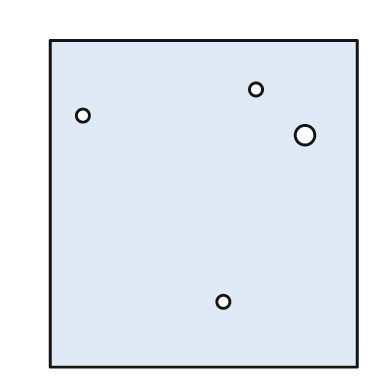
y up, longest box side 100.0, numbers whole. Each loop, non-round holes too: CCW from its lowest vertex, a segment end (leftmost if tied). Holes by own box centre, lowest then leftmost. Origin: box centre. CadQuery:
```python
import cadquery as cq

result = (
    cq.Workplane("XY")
    .moveTo(-47.0, -50.0)
    .lineTo(47.0, -50.0)
    .lineTo(47.0, 50.0)
    .lineTo(-47.0, 50.0)
    .close()
    .moveTo(6.0, -30.0)
    .circle(2.0)
    .moveTo(31.0, 21.0)
    .circle(3.0)
    .moveTo(-37.0, 27.0)
    .circle(2.0)
    .moveTo(16.0, 35.0)
    .circle(2.0)
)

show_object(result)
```